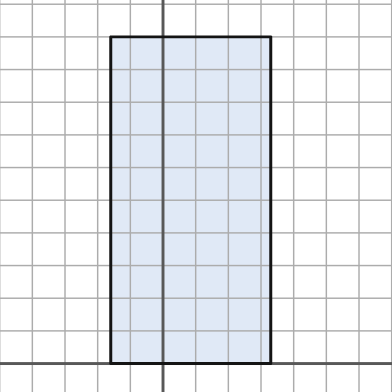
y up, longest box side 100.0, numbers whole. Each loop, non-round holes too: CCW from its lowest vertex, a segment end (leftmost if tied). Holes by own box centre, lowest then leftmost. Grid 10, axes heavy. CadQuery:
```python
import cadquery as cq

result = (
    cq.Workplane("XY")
    .moveTo(-16.0, 0.0)
    .lineTo(33.0, 0.0)
    .lineTo(33.0, 100.0)
    .lineTo(-16.0, 100.0)
    .close()
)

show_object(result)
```